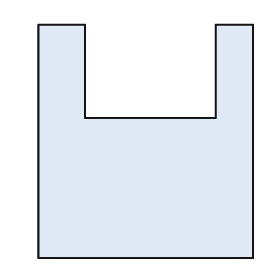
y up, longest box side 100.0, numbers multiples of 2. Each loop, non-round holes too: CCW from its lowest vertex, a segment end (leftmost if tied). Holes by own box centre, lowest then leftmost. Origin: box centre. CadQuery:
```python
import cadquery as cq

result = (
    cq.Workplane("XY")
    .moveTo(-46.0, -50.0)
    .lineTo(46.0, -50.0)
    .lineTo(46.0, 50.0)
    .lineTo(30.0, 50.0)
    .lineTo(30.0, 10.0)
    .lineTo(-26.0, 10.0)
    .lineTo(-26.0, 50.0)
    .lineTo(-46.0, 50.0)
    .close()
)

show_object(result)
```